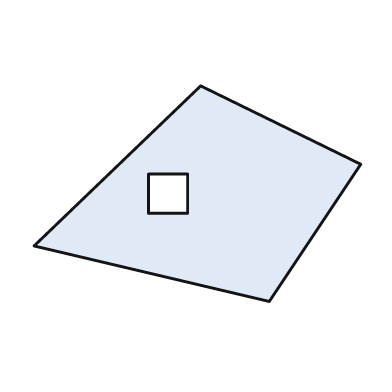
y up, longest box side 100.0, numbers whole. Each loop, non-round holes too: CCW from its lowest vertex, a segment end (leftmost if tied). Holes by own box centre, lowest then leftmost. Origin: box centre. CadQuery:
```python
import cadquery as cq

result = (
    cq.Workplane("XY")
    .moveTo(22.0, -33.0)
    .lineTo(50.0, 9.0)
    .lineTo(1.0, 33.0)
    .lineTo(-50.0, -16.0)
    .close()
    .moveTo(-15.0, -6.0)
    .lineTo(-3.0, -6.0)
    .lineTo(-3.0, 6.0)
    .lineTo(-15.0, 6.0)
    .close()
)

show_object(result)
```